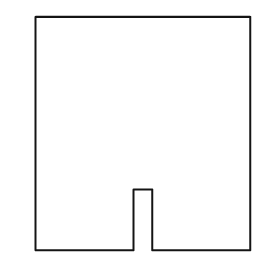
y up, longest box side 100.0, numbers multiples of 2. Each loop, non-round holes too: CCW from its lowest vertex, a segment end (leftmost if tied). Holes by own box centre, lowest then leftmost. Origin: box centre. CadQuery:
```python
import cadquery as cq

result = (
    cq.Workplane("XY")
    .moveTo(-46.0, -50.0)
    .lineTo(-4.0, -50.0)
    .lineTo(-4.0, -24.0)
    .lineTo(4.0, -24.0)
    .lineTo(4.0, -50.0)
    .lineTo(46.0, -50.0)
    .lineTo(46.0, 50.0)
    .lineTo(-46.0, 50.0)
    .close()
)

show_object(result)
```